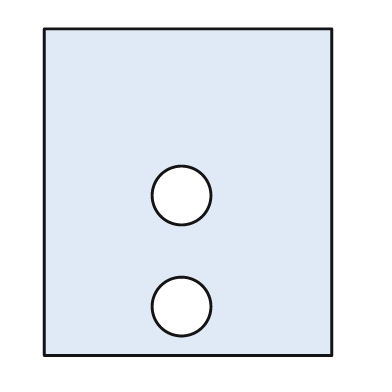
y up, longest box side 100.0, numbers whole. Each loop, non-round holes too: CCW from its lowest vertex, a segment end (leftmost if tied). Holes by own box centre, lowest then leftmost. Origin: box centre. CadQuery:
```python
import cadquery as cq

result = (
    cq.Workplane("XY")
    .moveTo(-44.0, -50.0)
    .lineTo(44.0, -50.0)
    .lineTo(44.0, 50.0)
    .lineTo(-44.0, 50.0)
    .close()
    .moveTo(-2.0, -35.0)
    .circle(9.0)
    .moveTo(-2.0, -1.0)
    .circle(9.0)
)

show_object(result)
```